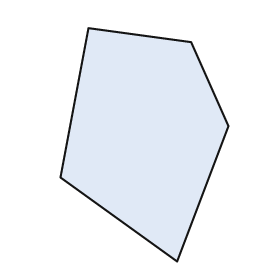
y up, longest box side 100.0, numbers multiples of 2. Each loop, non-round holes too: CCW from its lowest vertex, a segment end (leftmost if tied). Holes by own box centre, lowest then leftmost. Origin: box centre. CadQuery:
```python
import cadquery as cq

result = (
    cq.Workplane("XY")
    .moveTo(14.0, -50.0)
    .lineTo(36.0, 8.0)
    .lineTo(20.0, 44.0)
    .lineTo(-24.0, 50.0)
    .lineTo(-36.0, -14.0)
    .close()
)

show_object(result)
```